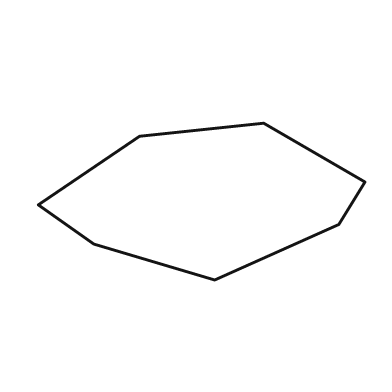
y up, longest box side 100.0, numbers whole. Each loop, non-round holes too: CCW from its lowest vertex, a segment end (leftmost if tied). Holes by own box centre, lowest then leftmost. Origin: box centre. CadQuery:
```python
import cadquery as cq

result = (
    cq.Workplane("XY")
    .moveTo(4.0, -24.0)
    .lineTo(42.0, -7.0)
    .lineTo(50.0, 6.0)
    .lineTo(19.0, 24.0)
    .lineTo(-19.0, 20.0)
    .lineTo(-50.0, -1.0)
    .lineTo(-33.0, -13.0)
    .close()
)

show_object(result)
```